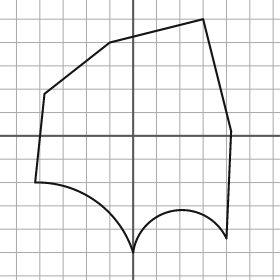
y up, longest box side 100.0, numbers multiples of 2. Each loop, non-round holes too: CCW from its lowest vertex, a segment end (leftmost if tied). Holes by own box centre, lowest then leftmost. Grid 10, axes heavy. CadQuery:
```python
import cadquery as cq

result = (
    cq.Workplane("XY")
    .moveTo(0.0, -50.0)
    .threePointArc((18.0, -32.0), (40.0, -44.0))
    .lineTo(42.0, 2.0)
    .lineTo(30.0, 50.0)
    .lineTo(-10.0, 40.0)
    .lineTo(-38.0, 18.0)
    .lineTo(-42.0, -20.0)
    .threePointArc((-16.0, -28.0), (0.0, -50.0))
    .close()
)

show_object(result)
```